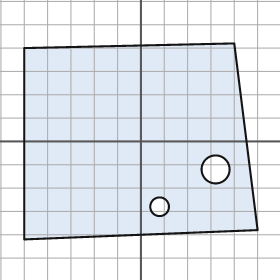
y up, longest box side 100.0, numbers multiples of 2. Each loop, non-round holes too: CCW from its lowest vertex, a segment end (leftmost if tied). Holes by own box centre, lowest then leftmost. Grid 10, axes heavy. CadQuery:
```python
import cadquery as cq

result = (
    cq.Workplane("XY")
    .moveTo(-50.0, -42.0)
    .lineTo(50.0, -38.0)
    .lineTo(40.0, 42.0)
    .lineTo(-50.0, 40.0)
    .close()
    .moveTo(8.0, -28.0)
    .circle(4.0)
    .moveTo(32.0, -12.0)
    .circle(6.0)
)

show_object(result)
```